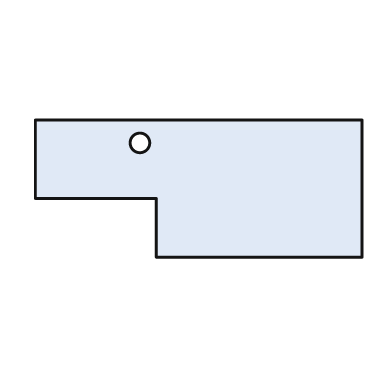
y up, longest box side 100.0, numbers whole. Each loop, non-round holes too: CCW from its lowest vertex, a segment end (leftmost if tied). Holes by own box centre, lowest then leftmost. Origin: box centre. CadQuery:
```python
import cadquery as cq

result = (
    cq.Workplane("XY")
    .moveTo(-13.0, -21.0)
    .lineTo(50.0, -21.0)
    .lineTo(50.0, 21.0)
    .lineTo(-50.0, 21.0)
    .lineTo(-50.0, -3.0)
    .lineTo(-13.0, -3.0)
    .close()
    .moveTo(-18.0, 14.0)
    .circle(3.0)
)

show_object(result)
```